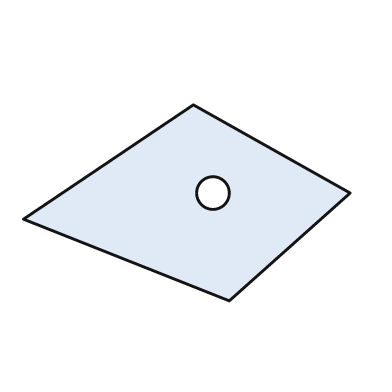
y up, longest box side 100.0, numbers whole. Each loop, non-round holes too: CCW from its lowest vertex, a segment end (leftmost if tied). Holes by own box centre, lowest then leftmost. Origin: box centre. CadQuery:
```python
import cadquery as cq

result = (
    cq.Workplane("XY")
    .moveTo(13.0, -30.0)
    .lineTo(50.0, 3.0)
    .lineTo(2.0, 30.0)
    .lineTo(-50.0, -5.0)
    .close()
    .moveTo(8.0, 3.0)
    .circle(5.0)
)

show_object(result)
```